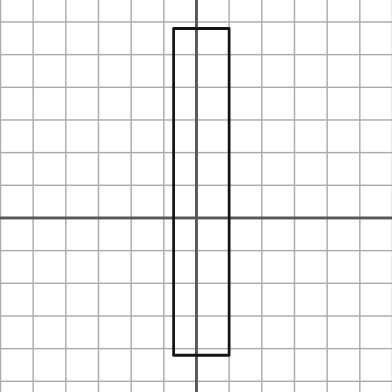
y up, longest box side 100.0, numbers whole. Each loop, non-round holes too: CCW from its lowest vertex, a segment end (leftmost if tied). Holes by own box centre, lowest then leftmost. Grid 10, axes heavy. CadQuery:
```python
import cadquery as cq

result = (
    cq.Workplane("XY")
    .moveTo(-7.0, -42.0)
    .lineTo(10.0, -42.0)
    .lineTo(10.0, 58.0)
    .lineTo(-7.0, 58.0)
    .close()
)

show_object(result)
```